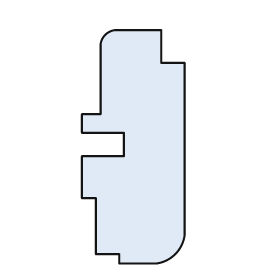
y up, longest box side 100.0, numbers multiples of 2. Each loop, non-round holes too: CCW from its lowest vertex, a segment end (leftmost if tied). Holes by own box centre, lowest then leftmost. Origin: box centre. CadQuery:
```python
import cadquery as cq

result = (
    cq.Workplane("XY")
    .moveTo(-6.0, -50.0)
    .lineTo(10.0, -50.0)
    .threePointArc((18.0, -46.0), (22.0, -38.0))
    .lineTo(22.0, 36.0)
    .lineTo(12.0, 36.0)
    .lineTo(12.0, 50.0)
    .lineTo(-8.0, 50.0)
    .threePointArc((-12.0, 48.0), (-14.0, 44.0))
    .lineTo(-14.0, 14.0)
    .lineTo(-22.0, 14.0)
    .lineTo(-22.0, 6.0)
    .lineTo(-4.0, 6.0)
    .lineTo(-4.0, -4.0)
    .lineTo(-22.0, -4.0)
    .lineTo(-22.0, -22.0)
    .lineTo(-16.0, -22.0)
    .lineTo(-16.0, -46.0)
    .lineTo(-6.0, -46.0)
    .close()
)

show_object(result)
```